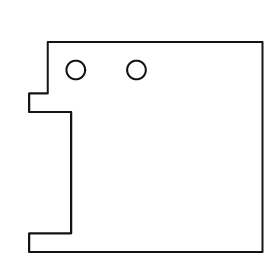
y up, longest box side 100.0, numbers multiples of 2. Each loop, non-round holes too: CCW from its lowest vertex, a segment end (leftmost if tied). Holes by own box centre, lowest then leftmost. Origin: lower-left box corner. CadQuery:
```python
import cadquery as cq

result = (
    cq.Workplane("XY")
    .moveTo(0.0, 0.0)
    .lineTo(100.0, 0.0)
    .lineTo(100.0, 90.0)
    .lineTo(8.0, 90.0)
    .lineTo(8.0, 68.0)
    .lineTo(0.0, 68.0)
    .lineTo(0.0, 60.0)
    .lineTo(18.0, 60.0)
    .lineTo(18.0, 8.0)
    .lineTo(0.0, 8.0)
    .close()
    .moveTo(20.0, 78.0)
    .circle(4.0)
    .moveTo(46.0, 78.0)
    .circle(4.0)
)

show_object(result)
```